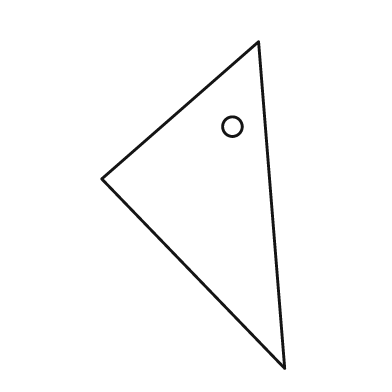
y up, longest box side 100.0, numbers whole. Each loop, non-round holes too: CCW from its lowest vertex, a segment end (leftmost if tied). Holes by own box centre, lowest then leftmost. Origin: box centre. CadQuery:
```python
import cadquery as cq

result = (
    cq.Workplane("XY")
    .moveTo(28.0, -50.0)
    .lineTo(20.0, 50.0)
    .lineTo(-28.0, 8.0)
    .close()
    .moveTo(12.0, 24.0)
    .circle(3.0)
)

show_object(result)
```